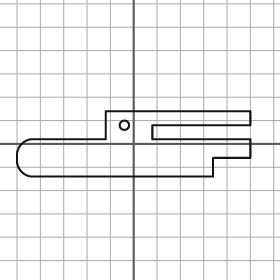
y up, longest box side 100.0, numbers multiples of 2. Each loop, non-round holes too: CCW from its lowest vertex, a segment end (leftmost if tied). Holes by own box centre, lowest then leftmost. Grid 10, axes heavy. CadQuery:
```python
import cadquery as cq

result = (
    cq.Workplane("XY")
    .moveTo(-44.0, -14.0)
    .lineTo(34.0, -14.0)
    .lineTo(34.0, -6.0)
    .lineTo(50.0, -6.0)
    .lineTo(50.0, 2.0)
    .lineTo(8.0, 2.0)
    .lineTo(8.0, 8.0)
    .lineTo(50.0, 8.0)
    .lineTo(50.0, 14.0)
    .lineTo(-12.0, 14.0)
    .lineTo(-12.0, 2.0)
    .lineTo(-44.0, 2.0)
    .threePointArc((-48.0, 0.0), (-50.0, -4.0))
    .lineTo(-50.0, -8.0)
    .threePointArc((-48.0, -12.0), (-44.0, -14.0))
    .close()
    .moveTo(-4.0, 8.0)
    .circle(2.0)
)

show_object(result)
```